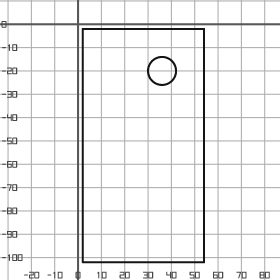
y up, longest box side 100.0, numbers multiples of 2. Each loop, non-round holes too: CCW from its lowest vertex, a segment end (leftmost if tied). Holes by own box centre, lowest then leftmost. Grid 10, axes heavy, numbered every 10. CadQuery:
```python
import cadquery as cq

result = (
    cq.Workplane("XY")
    .moveTo(2.0, -102.0)
    .lineTo(54.0, -102.0)
    .lineTo(54.0, -2.0)
    .lineTo(2.0, -2.0)
    .close()
    .moveTo(36.0, -20.0)
    .circle(6.0)
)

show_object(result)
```